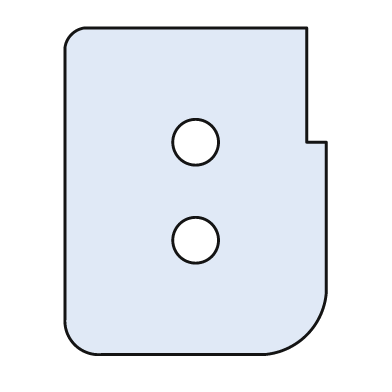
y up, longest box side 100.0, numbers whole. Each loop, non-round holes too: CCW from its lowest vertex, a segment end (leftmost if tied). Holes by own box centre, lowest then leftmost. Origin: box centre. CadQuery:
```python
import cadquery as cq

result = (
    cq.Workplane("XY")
    .moveTo(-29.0, -50.0)
    .lineTo(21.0, -50.0)
    .threePointArc((34.0, -44.0), (40.0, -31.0))
    .lineTo(40.0, 15.0)
    .lineTo(34.0, 15.0)
    .lineTo(34.0, 50.0)
    .lineTo(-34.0, 50.0)
    .threePointArc((-38.0, 48.0), (-40.0, 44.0))
    .lineTo(-40.0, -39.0)
    .threePointArc((-37.0, -47.0), (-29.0, -50.0))
    .close()
    .moveTo(0.0, -15.0)
    .circle(7.0)
    .moveTo(0.0, 15.0)
    .circle(7.0)
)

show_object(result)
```